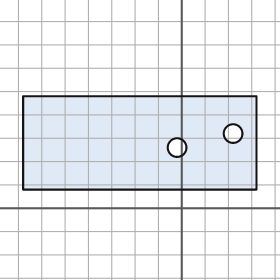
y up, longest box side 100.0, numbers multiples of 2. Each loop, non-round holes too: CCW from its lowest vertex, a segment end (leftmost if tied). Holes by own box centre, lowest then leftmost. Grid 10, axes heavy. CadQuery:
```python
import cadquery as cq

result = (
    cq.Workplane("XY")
    .moveTo(-68.0, 8.0)
    .lineTo(32.0, 8.0)
    .lineTo(32.0, 48.0)
    .lineTo(-68.0, 48.0)
    .close()
    .moveTo(-2.0, 26.0)
    .circle(4.0)
    .moveTo(22.0, 32.0)
    .circle(4.0)
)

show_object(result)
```